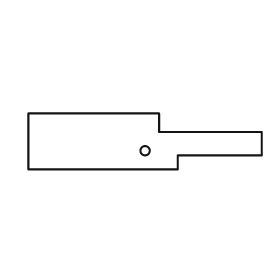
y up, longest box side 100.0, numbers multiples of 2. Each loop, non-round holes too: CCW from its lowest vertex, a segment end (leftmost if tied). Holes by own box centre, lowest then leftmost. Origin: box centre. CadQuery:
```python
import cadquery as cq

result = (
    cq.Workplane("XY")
    .moveTo(-50.0, -12.0)
    .lineTo(14.0, -12.0)
    .lineTo(14.0, -6.0)
    .lineTo(50.0, -6.0)
    .lineTo(50.0, 4.0)
    .lineTo(6.0, 4.0)
    .lineTo(6.0, 12.0)
    .lineTo(-50.0, 12.0)
    .close()
    .moveTo(0.0, -4.0)
    .circle(2.0)
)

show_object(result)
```